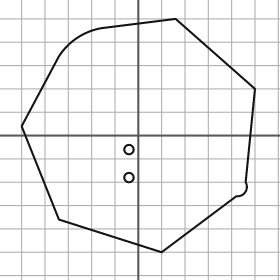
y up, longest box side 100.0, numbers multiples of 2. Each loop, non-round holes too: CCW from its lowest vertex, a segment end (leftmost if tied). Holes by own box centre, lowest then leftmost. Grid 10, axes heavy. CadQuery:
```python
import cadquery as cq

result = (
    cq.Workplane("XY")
    .moveTo(10.0, -50.0)
    .lineTo(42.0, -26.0)
    .threePointArc((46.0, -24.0), (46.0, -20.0))
    .lineTo(50.0, 20.0)
    .lineTo(16.0, 50.0)
    .lineTo(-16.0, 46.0)
    .threePointArc((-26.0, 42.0), (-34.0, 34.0))
    .lineTo(-50.0, 4.0)
    .lineTo(-34.0, -36.0)
    .close()
    .moveTo(-4.0, -18.0)
    .circle(2.0)
    .moveTo(-4.0, -6.0)
    .circle(2.0)
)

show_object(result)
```